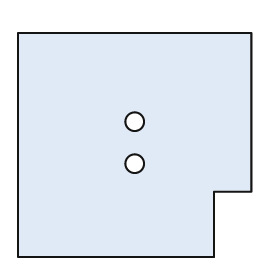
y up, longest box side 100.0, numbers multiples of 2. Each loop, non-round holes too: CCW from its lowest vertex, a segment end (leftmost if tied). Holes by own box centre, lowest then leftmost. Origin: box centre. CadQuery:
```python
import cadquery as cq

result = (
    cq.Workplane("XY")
    .moveTo(-50.0, -48.0)
    .lineTo(34.0, -48.0)
    .lineTo(34.0, -20.0)
    .lineTo(50.0, -20.0)
    .lineTo(50.0, 48.0)
    .lineTo(-50.0, 48.0)
    .close()
    .moveTo(0.0, -8.0)
    .circle(4.0)
    .moveTo(0.0, 10.0)
    .circle(4.0)
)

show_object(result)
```